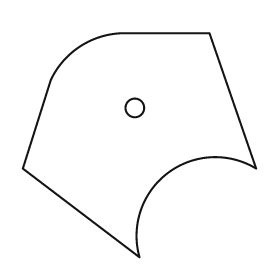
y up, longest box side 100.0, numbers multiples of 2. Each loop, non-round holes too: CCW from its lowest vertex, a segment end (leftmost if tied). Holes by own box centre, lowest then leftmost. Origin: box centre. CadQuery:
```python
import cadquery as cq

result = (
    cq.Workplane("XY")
    .moveTo(0.0, -48.0)
    .threePointArc((12.0, -12.0), (50.0, -10.0))
    .lineTo(30.0, 48.0)
    .lineTo(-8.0, 48.0)
    .threePointArc((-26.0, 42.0), (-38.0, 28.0))
    .lineTo(-50.0, -10.0)
    .close()
    .moveTo(-2.0, 16.0)
    .circle(4.0)
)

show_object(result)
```